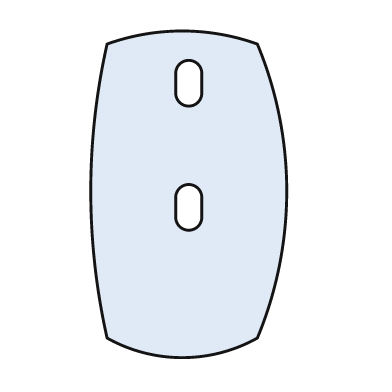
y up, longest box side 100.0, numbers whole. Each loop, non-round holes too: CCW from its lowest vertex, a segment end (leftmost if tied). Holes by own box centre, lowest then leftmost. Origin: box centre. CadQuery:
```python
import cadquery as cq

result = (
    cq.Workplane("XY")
    .moveTo(-25.0, -44.0)
    .threePointArc((-2.0, -50.0), (21.0, -44.0))
    .threePointArc((30.0, 1.0), (21.0, 46.0))
    .threePointArc((-2.0, 50.0), (-25.0, 46.0))
    .threePointArc((-30.0, 1.0), (-25.0, -44.0))
    .close()
    .moveTo(-4.0, -7.0)
    .threePointArc((0.0, -11.0), (4.0, -7.0))
    .lineTo(4.0, -1.0)
    .threePointArc((0.0, 3.0), (-4.0, -1.0))
    .close()
    .moveTo(-4.0, 31.0)
    .threePointArc((0.0, 27.0), (4.0, 31.0))
    .lineTo(4.0, 37.0)
    .threePointArc((0.0, 41.0), (-4.0, 37.0))
    .close()
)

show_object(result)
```